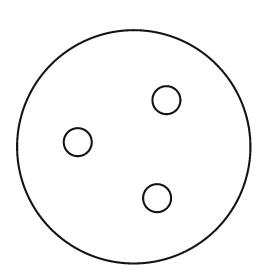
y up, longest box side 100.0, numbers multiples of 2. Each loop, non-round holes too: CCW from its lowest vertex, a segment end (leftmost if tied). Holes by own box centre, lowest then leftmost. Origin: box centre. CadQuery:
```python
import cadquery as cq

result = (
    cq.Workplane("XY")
    .moveTo(0.0, 0.0)
    .circle(50.0)
    .moveTo(10.0, -22.0)
    .circle(6.0)
    .moveTo(-24.0, 2.0)
    .circle(6.0)
    .moveTo(14.0, 20.0)
    .circle(6.0)
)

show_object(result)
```